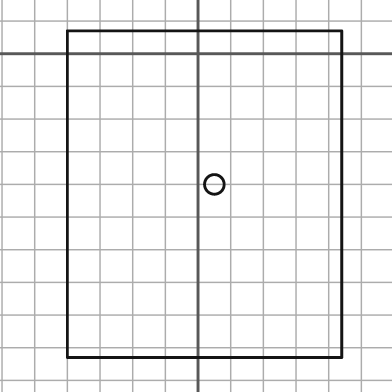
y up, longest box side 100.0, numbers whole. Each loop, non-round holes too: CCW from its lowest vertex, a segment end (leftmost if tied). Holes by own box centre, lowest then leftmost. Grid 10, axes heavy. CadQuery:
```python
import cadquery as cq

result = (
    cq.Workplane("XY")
    .moveTo(-40.0, -93.0)
    .lineTo(44.0, -93.0)
    .lineTo(44.0, 7.0)
    .lineTo(-40.0, 7.0)
    .close()
    .moveTo(5.0, -40.0)
    .circle(3.0)
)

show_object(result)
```